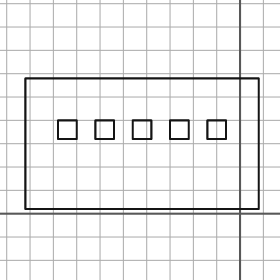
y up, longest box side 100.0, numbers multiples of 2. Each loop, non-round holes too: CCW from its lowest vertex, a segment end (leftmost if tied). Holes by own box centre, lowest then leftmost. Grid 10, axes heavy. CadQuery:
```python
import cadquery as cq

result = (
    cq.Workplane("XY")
    .moveTo(-92.0, 2.0)
    .lineTo(8.0, 2.0)
    .lineTo(8.0, 58.0)
    .lineTo(-92.0, 58.0)
    .close()
    .moveTo(-78.0, 32.0)
    .lineTo(-70.0, 32.0)
    .lineTo(-70.0, 40.0)
    .lineTo(-78.0, 40.0)
    .close()
    .moveTo(-62.0, 32.0)
    .lineTo(-54.0, 32.0)
    .lineTo(-54.0, 40.0)
    .lineTo(-62.0, 40.0)
    .close()
    .moveTo(-46.0, 32.0)
    .lineTo(-38.0, 32.0)
    .lineTo(-38.0, 40.0)
    .lineTo(-46.0, 40.0)
    .close()
    .moveTo(-30.0, 32.0)
    .lineTo(-22.0, 32.0)
    .lineTo(-22.0, 40.0)
    .lineTo(-30.0, 40.0)
    .close()
    .moveTo(-14.0, 32.0)
    .lineTo(-6.0, 32.0)
    .lineTo(-6.0, 40.0)
    .lineTo(-14.0, 40.0)
    .close()
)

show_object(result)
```